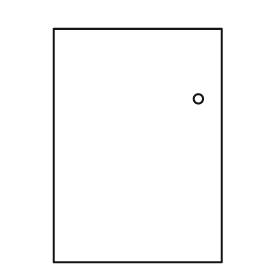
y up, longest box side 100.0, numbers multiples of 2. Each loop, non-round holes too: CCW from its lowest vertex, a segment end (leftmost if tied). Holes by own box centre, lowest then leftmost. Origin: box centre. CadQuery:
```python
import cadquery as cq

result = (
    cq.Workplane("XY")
    .moveTo(-36.0, -50.0)
    .lineTo(36.0, -50.0)
    .lineTo(36.0, 50.0)
    .lineTo(-36.0, 50.0)
    .close()
    .moveTo(26.0, 20.0)
    .circle(2.0)
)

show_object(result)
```